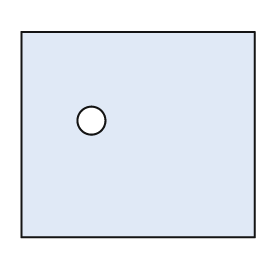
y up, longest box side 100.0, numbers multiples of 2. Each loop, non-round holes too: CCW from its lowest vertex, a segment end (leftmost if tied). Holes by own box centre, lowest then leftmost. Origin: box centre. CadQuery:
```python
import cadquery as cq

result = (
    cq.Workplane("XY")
    .moveTo(-50.0, -44.0)
    .lineTo(50.0, -44.0)
    .lineTo(50.0, 44.0)
    .lineTo(-50.0, 44.0)
    .close()
    .moveTo(-20.0, 6.0)
    .circle(6.0)
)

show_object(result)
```